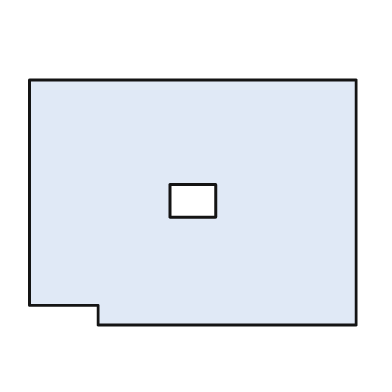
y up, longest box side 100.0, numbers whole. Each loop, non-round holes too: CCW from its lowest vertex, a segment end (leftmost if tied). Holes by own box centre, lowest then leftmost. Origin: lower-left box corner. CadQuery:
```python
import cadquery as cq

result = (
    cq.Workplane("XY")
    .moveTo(21.0, 0.0)
    .lineTo(100.0, 0.0)
    .lineTo(100.0, 75.0)
    .lineTo(0.0, 75.0)
    .lineTo(0.0, 6.0)
    .lineTo(21.0, 6.0)
    .close()
    .moveTo(43.0, 33.0)
    .lineTo(57.0, 33.0)
    .lineTo(57.0, 43.0)
    .lineTo(43.0, 43.0)
    .close()
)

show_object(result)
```